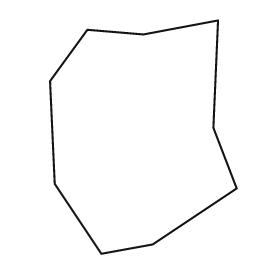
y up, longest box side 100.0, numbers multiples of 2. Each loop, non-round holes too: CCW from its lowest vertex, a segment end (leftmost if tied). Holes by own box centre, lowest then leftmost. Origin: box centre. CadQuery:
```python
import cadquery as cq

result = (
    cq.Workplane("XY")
    .moveTo(-18.0, -50.0)
    .lineTo(4.0, -46.0)
    .lineTo(40.0, -22.0)
    .lineTo(30.0, 4.0)
    .lineTo(32.0, 50.0)
    .lineTo(0.0, 44.0)
    .lineTo(-24.0, 46.0)
    .lineTo(-40.0, 24.0)
    .lineTo(-38.0, -20.0)
    .close()
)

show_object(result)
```